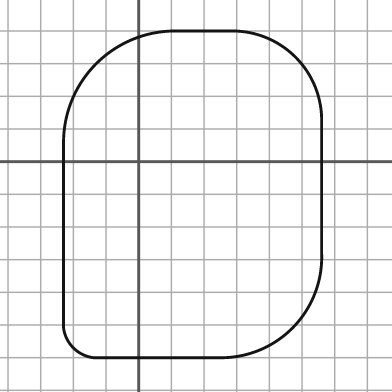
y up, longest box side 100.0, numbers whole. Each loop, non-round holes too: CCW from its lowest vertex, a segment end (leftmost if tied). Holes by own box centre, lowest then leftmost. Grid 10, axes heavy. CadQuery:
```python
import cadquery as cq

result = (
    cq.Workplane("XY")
    .moveTo(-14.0, -60.0)
    .lineTo(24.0, -60.0)
    .threePointArc((47.0, -51.0), (56.0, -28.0))
    .lineTo(56.0, 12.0)
    .threePointArc((48.0, 32.0), (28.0, 40.0))
    .lineTo(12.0, 40.0)
    .threePointArc((-13.0, 30.0), (-23.0, 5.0))
    .lineTo(-23.0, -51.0)
    .threePointArc((-20.0, -57.0), (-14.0, -60.0))
    .close()
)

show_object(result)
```